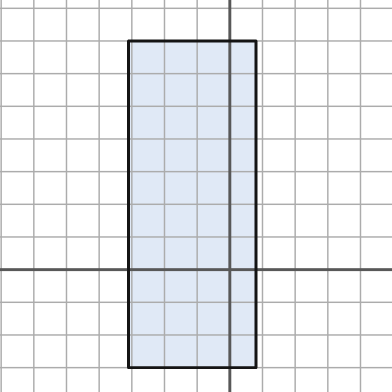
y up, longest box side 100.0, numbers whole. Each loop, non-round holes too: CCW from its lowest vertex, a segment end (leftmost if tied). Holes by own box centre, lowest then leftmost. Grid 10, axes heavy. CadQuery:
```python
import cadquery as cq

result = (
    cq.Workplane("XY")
    .moveTo(-31.0, -30.0)
    .lineTo(8.0, -30.0)
    .lineTo(8.0, 70.0)
    .lineTo(-31.0, 70.0)
    .close()
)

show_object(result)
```